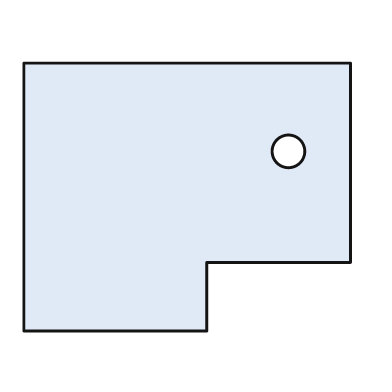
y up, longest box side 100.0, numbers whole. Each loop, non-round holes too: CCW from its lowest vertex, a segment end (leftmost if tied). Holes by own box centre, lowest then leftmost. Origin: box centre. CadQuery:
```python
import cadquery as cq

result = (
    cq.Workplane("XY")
    .moveTo(-50.0, -41.0)
    .lineTo(6.0, -41.0)
    .lineTo(6.0, -20.0)
    .lineTo(50.0, -20.0)
    .lineTo(50.0, 41.0)
    .lineTo(-50.0, 41.0)
    .close()
    .moveTo(31.0, 14.0)
    .circle(5.0)
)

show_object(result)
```